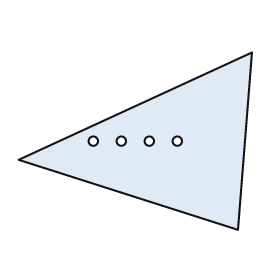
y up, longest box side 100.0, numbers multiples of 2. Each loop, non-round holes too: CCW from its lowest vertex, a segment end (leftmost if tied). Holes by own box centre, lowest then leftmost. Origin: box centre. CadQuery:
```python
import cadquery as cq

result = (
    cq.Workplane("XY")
    .moveTo(44.0, -38.0)
    .lineTo(50.0, 38.0)
    .lineTo(-50.0, -8.0)
    .close()
    .moveTo(-18.0, 0.0)
    .circle(2.0)
    .moveTo(-6.0, 0.0)
    .circle(2.0)
    .moveTo(6.0, 0.0)
    .circle(2.0)
    .moveTo(18.0, 0.0)
    .circle(2.0)
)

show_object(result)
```